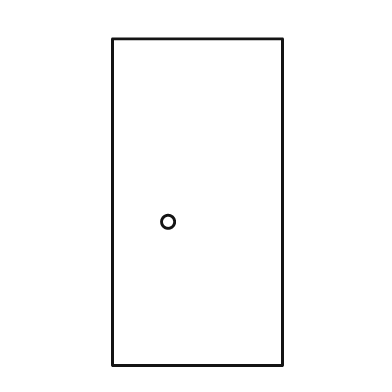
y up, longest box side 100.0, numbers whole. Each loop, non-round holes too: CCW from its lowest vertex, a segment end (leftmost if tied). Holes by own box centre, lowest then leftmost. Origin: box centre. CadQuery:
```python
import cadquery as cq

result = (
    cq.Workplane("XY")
    .moveTo(-26.0, -50.0)
    .lineTo(26.0, -50.0)
    .lineTo(26.0, 50.0)
    .lineTo(-26.0, 50.0)
    .close()
    .moveTo(-9.0, -6.0)
    .circle(2.0)
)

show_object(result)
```